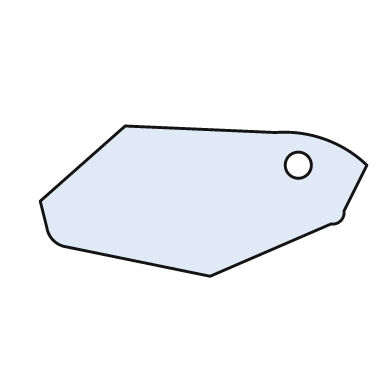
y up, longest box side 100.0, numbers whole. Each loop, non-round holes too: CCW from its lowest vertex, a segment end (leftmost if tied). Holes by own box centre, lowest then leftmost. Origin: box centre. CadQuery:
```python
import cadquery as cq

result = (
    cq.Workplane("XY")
    .moveTo(2.0, -23.0)
    .lineTo(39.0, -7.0)
    .threePointArc((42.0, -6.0), (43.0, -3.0))
    .lineTo(50.0, 11.0)
    .threePointArc((37.0, 19.0), (22.0, 21.0))
    .lineTo(-24.0, 23.0)
    .lineTo(-50.0, 0.0)
    .lineTo(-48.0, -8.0)
    .threePointArc((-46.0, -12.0), (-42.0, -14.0))
    .close()
    .moveTo(29.0, 11.0)
    .circle(4.0)
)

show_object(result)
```